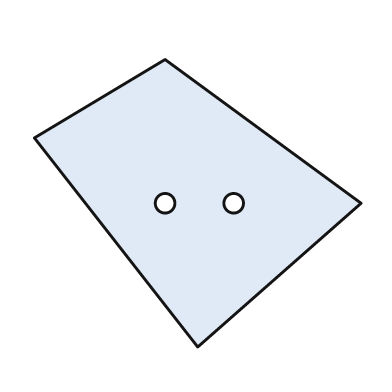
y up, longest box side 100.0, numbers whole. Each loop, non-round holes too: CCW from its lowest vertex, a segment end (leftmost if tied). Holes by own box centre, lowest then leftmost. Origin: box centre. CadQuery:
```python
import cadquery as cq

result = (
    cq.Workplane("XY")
    .moveTo(0.0, -44.0)
    .lineTo(50.0, 0.0)
    .lineTo(-10.0, 44.0)
    .lineTo(-50.0, 20.0)
    .close()
    .moveTo(-10.0, 0.0)
    .circle(3.0)
    .moveTo(11.0, 0.0)
    .circle(3.0)
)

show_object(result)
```